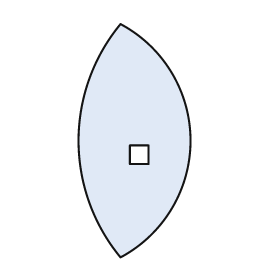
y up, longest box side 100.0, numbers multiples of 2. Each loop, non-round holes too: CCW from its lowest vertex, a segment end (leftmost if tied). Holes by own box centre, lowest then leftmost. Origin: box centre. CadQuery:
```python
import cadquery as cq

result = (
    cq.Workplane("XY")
    .moveTo(-6.0, -50.0)
    .threePointArc((24.0, 0.0), (-6.0, 50.0))
    .threePointArc((-24.0, 0.0), (-6.0, -50.0))
    .close()
    .moveTo(-2.0, -10.0)
    .lineTo(6.0, -10.0)
    .lineTo(6.0, -2.0)
    .lineTo(-2.0, -2.0)
    .close()
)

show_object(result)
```